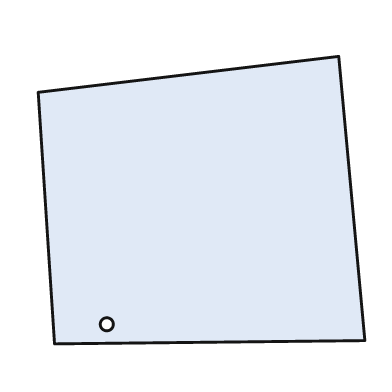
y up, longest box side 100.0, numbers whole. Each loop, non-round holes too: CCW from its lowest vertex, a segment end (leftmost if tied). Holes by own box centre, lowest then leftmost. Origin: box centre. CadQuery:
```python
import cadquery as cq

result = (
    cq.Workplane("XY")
    .moveTo(-45.0, -44.0)
    .lineTo(50.0, -43.0)
    .lineTo(42.0, 44.0)
    .lineTo(-50.0, 33.0)
    .close()
    .moveTo(-29.0, -38.0)
    .circle(2.0)
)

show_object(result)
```